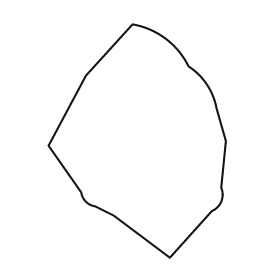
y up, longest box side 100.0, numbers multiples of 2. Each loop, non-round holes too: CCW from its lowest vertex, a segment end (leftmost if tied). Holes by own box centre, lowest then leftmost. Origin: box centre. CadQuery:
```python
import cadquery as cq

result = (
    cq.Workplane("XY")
    .moveTo(14.0, -50.0)
    .lineTo(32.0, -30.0)
    .threePointArc((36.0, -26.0), (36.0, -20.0))
    .lineTo(38.0, 0.0)
    .lineTo(34.0, 14.0)
    .threePointArc((30.0, 24.0), (22.0, 32.0))
    .threePointArc((12.0, 44.0), (-2.0, 50.0))
    .lineTo(-22.0, 28.0)
    .lineTo(-38.0, -2.0)
    .lineTo(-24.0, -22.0)
    .threePointArc((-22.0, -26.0), (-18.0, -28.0))
    .lineTo(-10.0, -32.0)
    .close()
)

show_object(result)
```